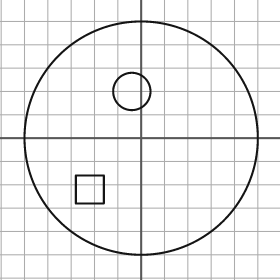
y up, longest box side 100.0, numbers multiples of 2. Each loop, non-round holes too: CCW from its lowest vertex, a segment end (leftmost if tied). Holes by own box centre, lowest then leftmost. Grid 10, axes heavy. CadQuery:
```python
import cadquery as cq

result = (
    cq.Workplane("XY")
    .moveTo(0.0, 0.0)
    .circle(50.0)
    .moveTo(-28.0, -28.0)
    .lineTo(-16.0, -28.0)
    .lineTo(-16.0, -16.0)
    .lineTo(-28.0, -16.0)
    .close()
    .moveTo(-4.0, 20.0)
    .circle(8.0)
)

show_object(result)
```